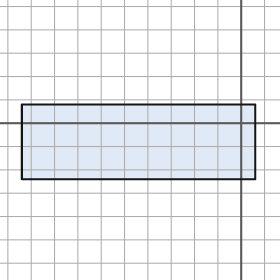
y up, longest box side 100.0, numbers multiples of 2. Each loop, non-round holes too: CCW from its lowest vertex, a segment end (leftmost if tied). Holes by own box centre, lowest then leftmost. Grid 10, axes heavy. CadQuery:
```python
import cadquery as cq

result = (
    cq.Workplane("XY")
    .moveTo(-94.0, -24.0)
    .lineTo(6.0, -24.0)
    .lineTo(6.0, 8.0)
    .lineTo(-94.0, 8.0)
    .close()
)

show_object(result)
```